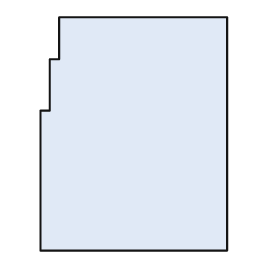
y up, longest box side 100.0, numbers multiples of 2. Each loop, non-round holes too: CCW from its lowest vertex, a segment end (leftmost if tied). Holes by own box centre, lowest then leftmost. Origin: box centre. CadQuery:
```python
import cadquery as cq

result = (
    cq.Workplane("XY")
    .moveTo(-40.0, -50.0)
    .lineTo(40.0, -50.0)
    .lineTo(40.0, 50.0)
    .lineTo(-32.0, 50.0)
    .lineTo(-32.0, 32.0)
    .lineTo(-36.0, 32.0)
    .lineTo(-36.0, 10.0)
    .lineTo(-40.0, 10.0)
    .close()
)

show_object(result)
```